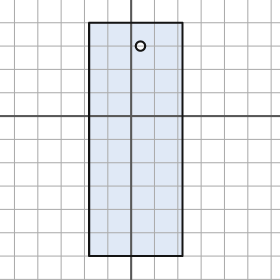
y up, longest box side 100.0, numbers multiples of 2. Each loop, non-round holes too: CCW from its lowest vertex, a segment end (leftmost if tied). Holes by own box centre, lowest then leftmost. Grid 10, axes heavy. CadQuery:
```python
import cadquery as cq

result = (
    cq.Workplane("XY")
    .moveTo(-18.0, -60.0)
    .lineTo(22.0, -60.0)
    .lineTo(22.0, 40.0)
    .lineTo(-18.0, 40.0)
    .close()
    .moveTo(4.0, 30.0)
    .circle(2.0)
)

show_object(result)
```